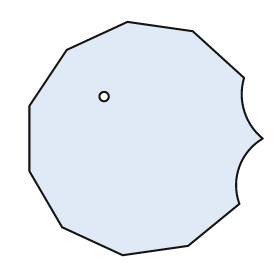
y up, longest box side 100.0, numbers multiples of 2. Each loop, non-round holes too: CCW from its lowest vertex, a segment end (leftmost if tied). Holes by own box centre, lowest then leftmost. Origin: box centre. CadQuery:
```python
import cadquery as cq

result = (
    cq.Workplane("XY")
    .moveTo(-10.0, -50.0)
    .lineTo(18.0, -46.0)
    .lineTo(40.0, -28.0)
    .threePointArc((40.0, -12.0), (50.0, 0.0))
    .threePointArc((42.0, 12.0), (42.0, 26.0))
    .lineTo(20.0, 46.0)
    .lineTo(-8.0, 50.0)
    .lineTo(-34.0, 38.0)
    .lineTo(-50.0, 14.0)
    .lineTo(-50.0, -14.0)
    .lineTo(-36.0, -38.0)
    .close()
    .moveTo(-18.0, 18.0)
    .circle(2.0)
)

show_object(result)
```